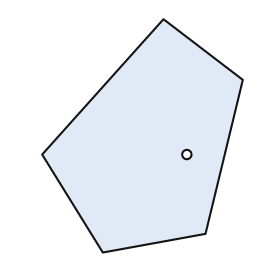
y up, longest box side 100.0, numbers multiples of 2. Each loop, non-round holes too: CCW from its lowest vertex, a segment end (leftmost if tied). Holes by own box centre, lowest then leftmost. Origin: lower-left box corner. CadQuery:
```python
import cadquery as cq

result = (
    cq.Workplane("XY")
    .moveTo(26.0, 0.0)
    .lineTo(70.0, 8.0)
    .lineTo(86.0, 74.0)
    .lineTo(52.0, 100.0)
    .lineTo(0.0, 42.0)
    .close()
    .moveTo(62.0, 42.0)
    .circle(2.0)
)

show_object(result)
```